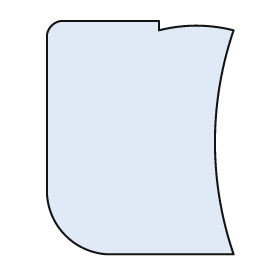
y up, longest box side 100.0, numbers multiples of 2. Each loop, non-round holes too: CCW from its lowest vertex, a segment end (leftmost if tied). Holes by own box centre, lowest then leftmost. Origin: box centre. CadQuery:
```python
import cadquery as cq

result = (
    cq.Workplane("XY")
    .moveTo(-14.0, -50.0)
    .lineTo(40.0, -50.0)
    .threePointArc((32.0, -2.0), (40.0, 46.0))
    .threePointArc((24.0, 48.0), (8.0, 46.0))
    .lineTo(8.0, 50.0)
    .lineTo(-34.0, 50.0)
    .threePointArc((-38.0, 48.0), (-40.0, 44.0))
    .lineTo(-40.0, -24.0)
    .threePointArc((-32.0, -42.0), (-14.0, -50.0))
    .close()
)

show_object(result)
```